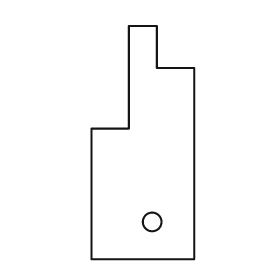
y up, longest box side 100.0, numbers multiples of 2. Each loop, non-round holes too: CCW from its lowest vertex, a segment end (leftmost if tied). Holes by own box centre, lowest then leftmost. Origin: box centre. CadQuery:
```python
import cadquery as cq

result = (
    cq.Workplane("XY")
    .moveTo(-22.0, -50.0)
    .lineTo(22.0, -50.0)
    .lineTo(22.0, 32.0)
    .lineTo(6.0, 32.0)
    .lineTo(6.0, 50.0)
    .lineTo(-6.0, 50.0)
    .lineTo(-6.0, 6.0)
    .lineTo(-22.0, 6.0)
    .close()
    .moveTo(4.0, -34.0)
    .circle(4.0)
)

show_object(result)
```